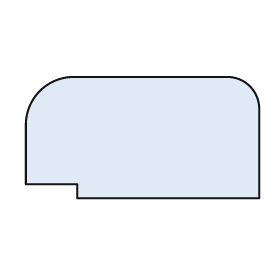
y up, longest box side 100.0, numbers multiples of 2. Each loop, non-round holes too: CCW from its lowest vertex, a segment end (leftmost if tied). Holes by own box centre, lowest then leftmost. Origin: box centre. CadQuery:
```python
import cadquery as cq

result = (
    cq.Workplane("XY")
    .moveTo(-28.0, -26.0)
    .lineTo(50.0, -26.0)
    .lineTo(50.0, 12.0)
    .threePointArc((46.0, 22.0), (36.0, 26.0))
    .lineTo(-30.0, 26.0)
    .threePointArc((-44.0, 20.0), (-50.0, 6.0))
    .lineTo(-50.0, -20.0)
    .lineTo(-28.0, -20.0)
    .close()
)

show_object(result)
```